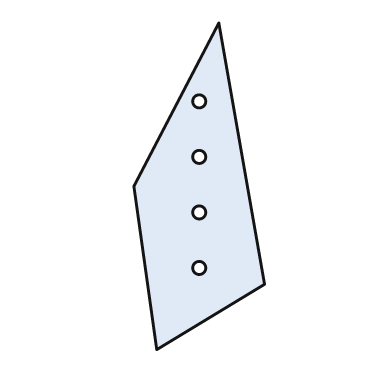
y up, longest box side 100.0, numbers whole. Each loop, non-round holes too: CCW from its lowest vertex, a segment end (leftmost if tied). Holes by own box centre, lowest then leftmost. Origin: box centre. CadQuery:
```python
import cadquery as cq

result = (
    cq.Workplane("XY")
    .moveTo(-13.0, -50.0)
    .lineTo(20.0, -30.0)
    .lineTo(6.0, 50.0)
    .lineTo(-20.0, 0.0)
    .close()
    .moveTo(0.0, -25.0)
    .circle(2.0)
    .moveTo(0.0, -8.0)
    .circle(2.0)
    .moveTo(0.0, 9.0)
    .circle(2.0)
    .moveTo(0.0, 26.0)
    .circle(2.0)
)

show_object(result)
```